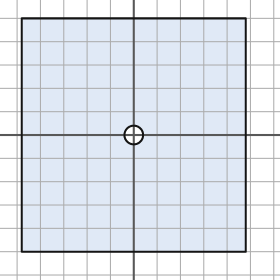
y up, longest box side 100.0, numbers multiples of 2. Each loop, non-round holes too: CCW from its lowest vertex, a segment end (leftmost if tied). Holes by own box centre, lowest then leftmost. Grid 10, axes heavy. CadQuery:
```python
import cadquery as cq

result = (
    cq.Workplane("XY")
    .moveTo(-48.0, -50.0)
    .lineTo(48.0, -50.0)
    .lineTo(48.0, 50.0)
    .lineTo(-48.0, 50.0)
    .close()
    .moveTo(0.0, 0.0)
    .circle(4.0)
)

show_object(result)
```